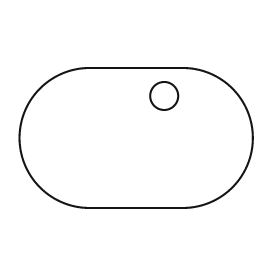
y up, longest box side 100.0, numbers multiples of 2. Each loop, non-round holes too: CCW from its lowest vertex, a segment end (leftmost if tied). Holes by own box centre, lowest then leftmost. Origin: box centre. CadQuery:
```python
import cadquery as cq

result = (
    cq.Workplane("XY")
    .moveTo(-20.0, -30.0)
    .lineTo(20.0, -30.0)
    .threePointArc((50.0, 0.0), (20.0, 30.0))
    .lineTo(-20.0, 30.0)
    .threePointArc((-50.0, 0.0), (-20.0, -30.0))
    .close()
    .moveTo(12.0, 18.0)
    .circle(6.0)
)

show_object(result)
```